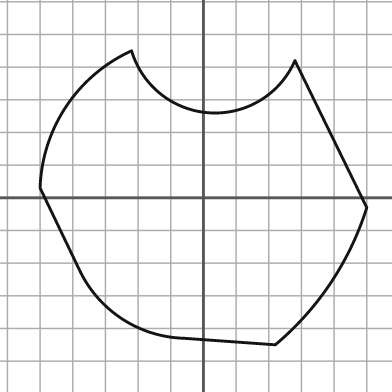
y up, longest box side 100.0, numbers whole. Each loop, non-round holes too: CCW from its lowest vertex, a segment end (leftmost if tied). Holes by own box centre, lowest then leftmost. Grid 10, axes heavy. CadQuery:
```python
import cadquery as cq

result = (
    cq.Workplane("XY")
    .moveTo(22.0, -45.0)
    .threePointArc((39.0, -26.0), (50.0, -3.0))
    .lineTo(28.0, 42.0)
    .threePointArc((2.0, 26.0), (-22.0, 45.0))
    .threePointArc((-42.0, 28.0), (-50.0, 3.0))
    .lineTo(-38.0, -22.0)
    .threePointArc((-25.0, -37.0), (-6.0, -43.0))
    .close()
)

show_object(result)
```